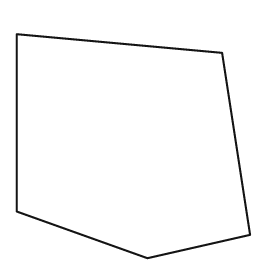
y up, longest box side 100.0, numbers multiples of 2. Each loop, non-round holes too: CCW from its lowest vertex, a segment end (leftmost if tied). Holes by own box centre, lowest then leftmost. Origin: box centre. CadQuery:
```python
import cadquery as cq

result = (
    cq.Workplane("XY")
    .moveTo(6.0, -48.0)
    .lineTo(50.0, -38.0)
    .lineTo(38.0, 40.0)
    .lineTo(-50.0, 48.0)
    .lineTo(-50.0, -28.0)
    .close()
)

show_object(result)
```